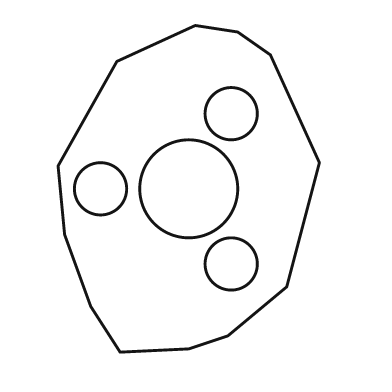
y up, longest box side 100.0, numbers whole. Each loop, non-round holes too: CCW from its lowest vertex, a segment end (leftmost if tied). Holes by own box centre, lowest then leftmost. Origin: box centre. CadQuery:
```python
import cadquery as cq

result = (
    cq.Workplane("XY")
    .moveTo(-21.0, -50.0)
    .lineTo(0.0, -49.0)
    .lineTo(12.0, -45.0)
    .lineTo(30.0, -30.0)
    .lineTo(40.0, 8.0)
    .lineTo(25.0, 41.0)
    .lineTo(15.0, 48.0)
    .lineTo(2.0, 50.0)
    .lineTo(-22.0, 39.0)
    .lineTo(-40.0, 7.0)
    .lineTo(-38.0, -14.0)
    .lineTo(-30.0, -36.0)
    .close()
    .moveTo(13.0, -23.0)
    .circle(8.0)
    .moveTo(-27.0, 0.0)
    .circle(8.0)
    .moveTo(0.0, 0.0)
    .circle(15.0)
    .moveTo(13.0, 23.0)
    .circle(8.0)
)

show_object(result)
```